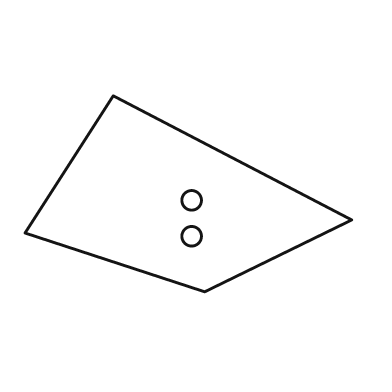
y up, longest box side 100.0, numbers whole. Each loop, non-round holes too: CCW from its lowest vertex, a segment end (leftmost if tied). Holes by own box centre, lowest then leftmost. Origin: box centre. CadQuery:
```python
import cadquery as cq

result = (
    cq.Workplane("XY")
    .moveTo(5.0, -30.0)
    .lineTo(50.0, -8.0)
    .lineTo(-23.0, 30.0)
    .lineTo(-50.0, -12.0)
    .close()
    .moveTo(1.0, -13.0)
    .circle(3.0)
    .moveTo(1.0, -2.0)
    .circle(3.0)
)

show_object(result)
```